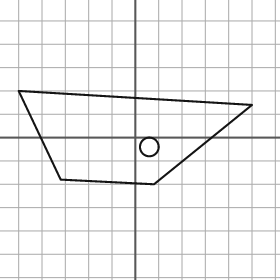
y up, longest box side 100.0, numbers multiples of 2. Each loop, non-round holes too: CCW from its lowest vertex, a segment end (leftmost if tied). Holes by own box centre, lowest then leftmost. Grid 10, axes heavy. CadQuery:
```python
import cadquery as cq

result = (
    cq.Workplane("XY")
    .moveTo(8.0, -20.0)
    .lineTo(50.0, 14.0)
    .lineTo(-50.0, 20.0)
    .lineTo(-32.0, -18.0)
    .close()
    .moveTo(6.0, -4.0)
    .circle(4.0)
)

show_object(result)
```